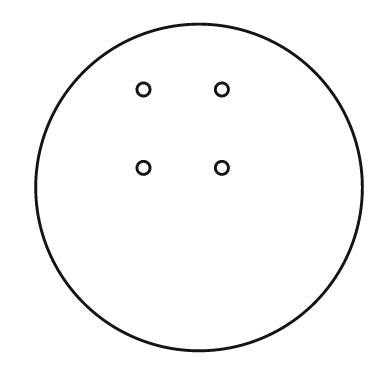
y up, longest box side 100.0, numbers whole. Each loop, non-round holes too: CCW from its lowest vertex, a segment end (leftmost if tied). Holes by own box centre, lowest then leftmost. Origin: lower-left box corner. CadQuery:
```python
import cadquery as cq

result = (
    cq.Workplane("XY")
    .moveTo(50.0, 50.0)
    .circle(50.0)
    .moveTo(33.0, 56.0)
    .circle(2.0)
    .moveTo(57.0, 56.0)
    .circle(2.0)
    .moveTo(33.0, 80.0)
    .circle(2.0)
    .moveTo(57.0, 80.0)
    .circle(2.0)
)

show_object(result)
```